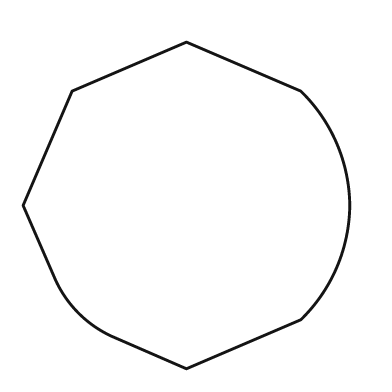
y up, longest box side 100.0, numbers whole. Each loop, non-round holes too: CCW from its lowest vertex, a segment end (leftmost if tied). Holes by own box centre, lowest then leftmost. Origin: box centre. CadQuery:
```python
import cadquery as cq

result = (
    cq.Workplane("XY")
    .moveTo(0.0, -50.0)
    .lineTo(35.0, -35.0)
    .threePointArc((46.0, -19.0), (50.0, 0.0))
    .threePointArc((46.0, 19.0), (35.0, 35.0))
    .lineTo(0.0, 50.0)
    .lineTo(-35.0, 35.0)
    .lineTo(-50.0, 0.0)
    .lineTo(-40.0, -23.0)
    .threePointArc((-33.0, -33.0), (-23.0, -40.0))
    .close()
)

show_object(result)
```